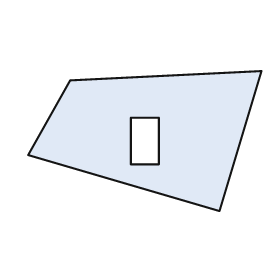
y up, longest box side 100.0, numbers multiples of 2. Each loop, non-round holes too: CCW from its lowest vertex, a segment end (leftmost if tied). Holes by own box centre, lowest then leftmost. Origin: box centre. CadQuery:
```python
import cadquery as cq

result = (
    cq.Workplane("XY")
    .moveTo(32.0, -30.0)
    .lineTo(50.0, 30.0)
    .lineTo(-32.0, 26.0)
    .lineTo(-50.0, -6.0)
    .close()
    .moveTo(-6.0, -10.0)
    .lineTo(6.0, -10.0)
    .lineTo(6.0, 10.0)
    .lineTo(-6.0, 10.0)
    .close()
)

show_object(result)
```